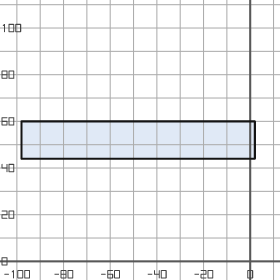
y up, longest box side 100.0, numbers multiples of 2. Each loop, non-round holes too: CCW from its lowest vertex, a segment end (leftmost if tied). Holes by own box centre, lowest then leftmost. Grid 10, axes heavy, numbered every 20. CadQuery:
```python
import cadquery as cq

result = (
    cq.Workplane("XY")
    .moveTo(-98.0, 44.0)
    .lineTo(2.0, 44.0)
    .lineTo(2.0, 60.0)
    .lineTo(-98.0, 60.0)
    .close()
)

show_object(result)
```